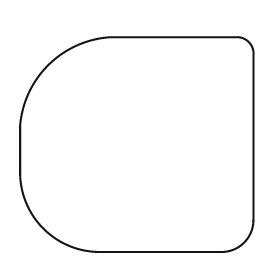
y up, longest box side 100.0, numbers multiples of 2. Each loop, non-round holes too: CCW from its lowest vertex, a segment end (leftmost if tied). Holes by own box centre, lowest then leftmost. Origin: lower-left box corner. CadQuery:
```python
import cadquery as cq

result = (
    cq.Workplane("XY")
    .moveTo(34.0, 0.0)
    .lineTo(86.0, 0.0)
    .threePointArc((96.0, 4.0), (100.0, 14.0))
    .lineTo(100.0, 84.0)
    .threePointArc((98.0, 90.0), (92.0, 92.0))
    .lineTo(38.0, 92.0)
    .threePointArc((12.0, 80.0), (0.0, 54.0))
    .lineTo(0.0, 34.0)
    .threePointArc((10.0, 10.0), (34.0, 0.0))
    .close()
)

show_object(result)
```